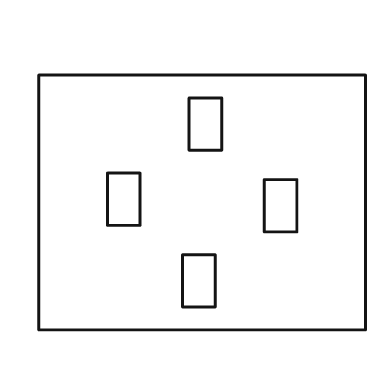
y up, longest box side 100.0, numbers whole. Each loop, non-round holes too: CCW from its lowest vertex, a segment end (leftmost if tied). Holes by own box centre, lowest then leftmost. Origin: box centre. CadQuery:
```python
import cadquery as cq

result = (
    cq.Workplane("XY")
    .moveTo(-50.0, -39.0)
    .lineTo(50.0, -39.0)
    .lineTo(50.0, 39.0)
    .lineTo(-50.0, 39.0)
    .close()
    .moveTo(-6.0, -32.0)
    .lineTo(4.0, -32.0)
    .lineTo(4.0, -16.0)
    .lineTo(-6.0, -16.0)
    .close()
    .moveTo(19.0, -9.0)
    .lineTo(29.0, -9.0)
    .lineTo(29.0, 7.0)
    .lineTo(19.0, 7.0)
    .close()
    .moveTo(-29.0, -7.0)
    .lineTo(-19.0, -7.0)
    .lineTo(-19.0, 9.0)
    .lineTo(-29.0, 9.0)
    .close()
    .moveTo(-4.0, 16.0)
    .lineTo(6.0, 16.0)
    .lineTo(6.0, 32.0)
    .lineTo(-4.0, 32.0)
    .close()
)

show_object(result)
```